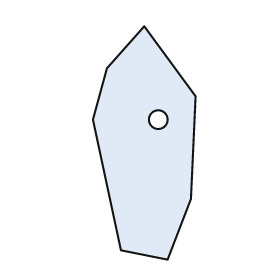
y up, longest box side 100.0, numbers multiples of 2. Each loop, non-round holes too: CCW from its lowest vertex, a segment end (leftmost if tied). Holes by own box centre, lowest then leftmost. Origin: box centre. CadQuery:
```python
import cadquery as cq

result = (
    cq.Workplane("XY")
    .moveTo(10.0, -50.0)
    .lineTo(20.0, -24.0)
    .lineTo(22.0, 20.0)
    .lineTo(0.0, 50.0)
    .lineTo(-16.0, 32.0)
    .lineTo(-22.0, 10.0)
    .lineTo(-10.0, -46.0)
    .close()
    .moveTo(6.0, 10.0)
    .circle(4.0)
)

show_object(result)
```